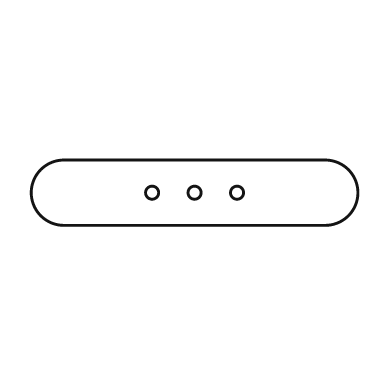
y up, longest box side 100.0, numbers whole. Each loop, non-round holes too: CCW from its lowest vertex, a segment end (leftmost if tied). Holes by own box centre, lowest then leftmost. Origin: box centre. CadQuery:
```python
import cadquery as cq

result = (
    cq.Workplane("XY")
    .moveTo(-40.0, -10.0)
    .lineTo(40.0, -10.0)
    .threePointArc((50.0, 0.0), (40.0, 10.0))
    .lineTo(-40.0, 10.0)
    .threePointArc((-50.0, 0.0), (-40.0, -10.0))
    .close()
    .moveTo(-13.0, 0.0)
    .circle(2.0)
    .moveTo(0.0, 0.0)
    .circle(2.0)
    .moveTo(13.0, 0.0)
    .circle(2.0)
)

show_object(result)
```